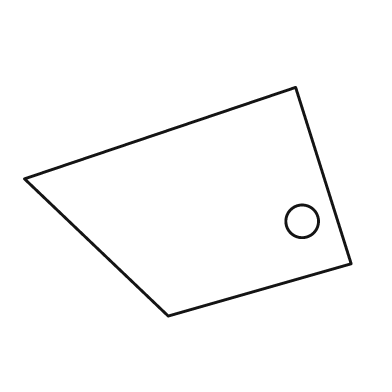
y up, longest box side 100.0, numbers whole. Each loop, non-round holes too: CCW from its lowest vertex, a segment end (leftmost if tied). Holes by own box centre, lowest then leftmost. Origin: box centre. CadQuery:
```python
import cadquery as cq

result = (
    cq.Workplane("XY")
    .moveTo(-6.0, -35.0)
    .lineTo(50.0, -19.0)
    .lineTo(33.0, 35.0)
    .lineTo(-50.0, 7.0)
    .close()
    .moveTo(35.0, -6.0)
    .circle(5.0)
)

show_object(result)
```